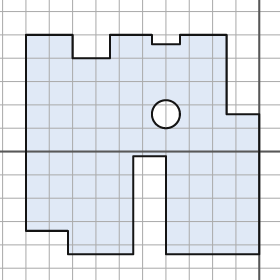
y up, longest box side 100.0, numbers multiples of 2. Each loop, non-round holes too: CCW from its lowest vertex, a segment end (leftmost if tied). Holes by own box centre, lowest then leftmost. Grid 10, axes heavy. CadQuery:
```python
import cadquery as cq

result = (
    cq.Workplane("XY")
    .moveTo(-82.0, -44.0)
    .lineTo(-54.0, -44.0)
    .lineTo(-54.0, -2.0)
    .lineTo(-40.0, -2.0)
    .lineTo(-40.0, -44.0)
    .lineTo(0.0, -44.0)
    .lineTo(0.0, 16.0)
    .lineTo(-14.0, 16.0)
    .lineTo(-14.0, 50.0)
    .lineTo(-34.0, 50.0)
    .lineTo(-34.0, 46.0)
    .lineTo(-46.0, 46.0)
    .lineTo(-46.0, 50.0)
    .lineTo(-64.0, 50.0)
    .lineTo(-64.0, 40.0)
    .lineTo(-80.0, 40.0)
    .lineTo(-80.0, 50.0)
    .lineTo(-100.0, 50.0)
    .lineTo(-100.0, -34.0)
    .lineTo(-82.0, -34.0)
    .close()
    .moveTo(-40.0, 16.0)
    .circle(6.0)
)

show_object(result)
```